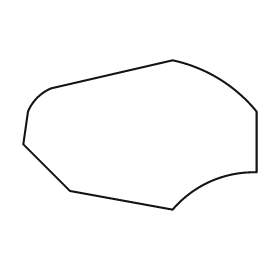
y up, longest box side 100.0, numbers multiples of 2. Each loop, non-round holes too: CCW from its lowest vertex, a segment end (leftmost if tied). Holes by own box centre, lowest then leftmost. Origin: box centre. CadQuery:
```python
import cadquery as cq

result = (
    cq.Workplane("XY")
    .moveTo(14.0, -32.0)
    .threePointArc((30.0, -20.0), (50.0, -16.0))
    .lineTo(50.0, 10.0)
    .threePointArc((34.0, 24.0), (14.0, 32.0))
    .lineTo(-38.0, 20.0)
    .threePointArc((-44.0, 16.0), (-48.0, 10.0))
    .lineTo(-50.0, -4.0)
    .lineTo(-30.0, -24.0)
    .close()
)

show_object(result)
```